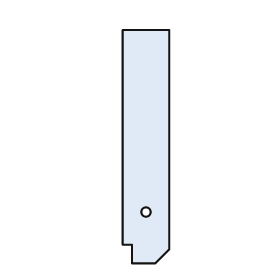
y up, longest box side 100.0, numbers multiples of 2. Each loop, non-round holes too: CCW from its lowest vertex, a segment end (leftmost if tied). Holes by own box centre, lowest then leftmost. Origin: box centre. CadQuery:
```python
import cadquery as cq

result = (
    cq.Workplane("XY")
    .moveTo(-6.0, -50.0)
    .lineTo(4.0, -50.0)
    .lineTo(10.0, -44.0)
    .lineTo(10.0, 50.0)
    .lineTo(-10.0, 50.0)
    .lineTo(-10.0, -42.0)
    .lineTo(-6.0, -42.0)
    .close()
    .moveTo(0.0, -28.0)
    .circle(2.0)
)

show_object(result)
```